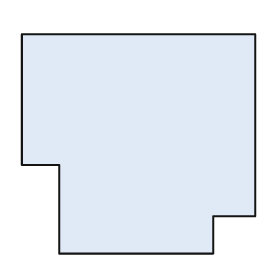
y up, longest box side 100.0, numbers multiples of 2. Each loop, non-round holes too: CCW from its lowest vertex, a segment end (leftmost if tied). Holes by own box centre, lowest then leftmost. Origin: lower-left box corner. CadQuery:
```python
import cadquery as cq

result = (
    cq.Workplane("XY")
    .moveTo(16.0, 0.0)
    .lineTo(82.0, 0.0)
    .lineTo(82.0, 16.0)
    .lineTo(100.0, 16.0)
    .lineTo(100.0, 94.0)
    .lineTo(0.0, 94.0)
    .lineTo(0.0, 38.0)
    .lineTo(16.0, 38.0)
    .close()
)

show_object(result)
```